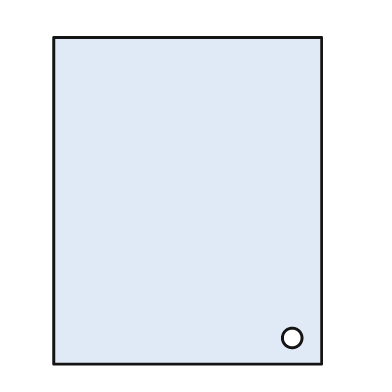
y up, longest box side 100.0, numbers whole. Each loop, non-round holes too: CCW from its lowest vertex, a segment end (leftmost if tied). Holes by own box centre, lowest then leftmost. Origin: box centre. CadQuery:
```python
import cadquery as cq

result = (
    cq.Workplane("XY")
    .moveTo(-41.0, -50.0)
    .lineTo(41.0, -50.0)
    .lineTo(41.0, 50.0)
    .lineTo(-41.0, 50.0)
    .close()
    .moveTo(32.0, -42.0)
    .circle(3.0)
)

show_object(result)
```